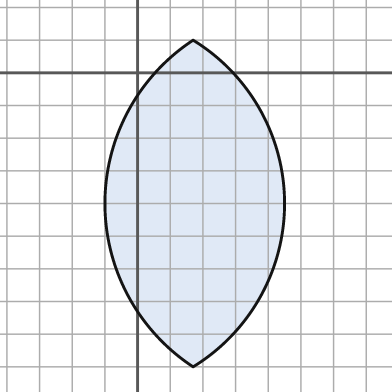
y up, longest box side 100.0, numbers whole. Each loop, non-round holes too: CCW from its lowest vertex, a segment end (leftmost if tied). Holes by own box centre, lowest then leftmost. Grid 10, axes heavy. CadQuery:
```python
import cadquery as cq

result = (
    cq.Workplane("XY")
    .moveTo(17.0, -90.0)
    .threePointArc((45.0, -40.0), (17.0, 10.0))
    .threePointArc((-10.0, -40.0), (17.0, -90.0))
    .close()
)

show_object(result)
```